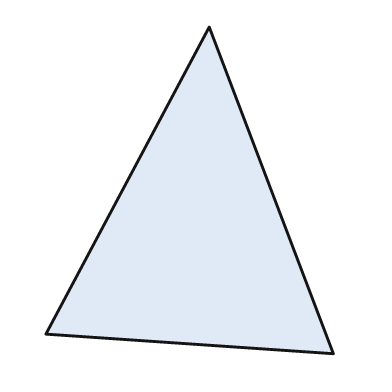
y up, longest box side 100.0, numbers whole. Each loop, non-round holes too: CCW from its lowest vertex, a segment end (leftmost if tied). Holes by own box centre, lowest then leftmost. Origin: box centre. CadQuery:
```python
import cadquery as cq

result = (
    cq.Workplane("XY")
    .moveTo(44.0, -50.0)
    .lineTo(6.0, 50.0)
    .lineTo(-44.0, -44.0)
    .close()
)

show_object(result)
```